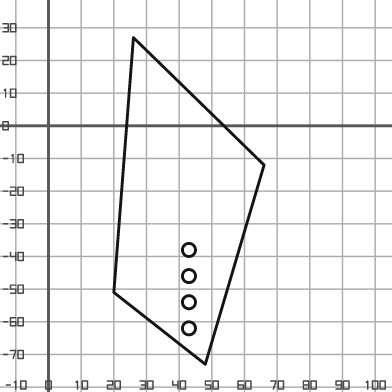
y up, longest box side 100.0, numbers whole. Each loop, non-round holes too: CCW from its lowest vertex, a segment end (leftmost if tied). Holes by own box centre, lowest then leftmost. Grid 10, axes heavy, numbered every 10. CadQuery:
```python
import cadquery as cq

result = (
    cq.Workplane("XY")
    .moveTo(48.0, -73.0)
    .lineTo(66.0, -12.0)
    .lineTo(26.0, 27.0)
    .lineTo(20.0, -51.0)
    .close()
    .moveTo(43.0, -62.0)
    .circle(2.0)
    .moveTo(43.0, -54.0)
    .circle(2.0)
    .moveTo(43.0, -46.0)
    .circle(2.0)
    .moveTo(43.0, -38.0)
    .circle(2.0)
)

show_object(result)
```